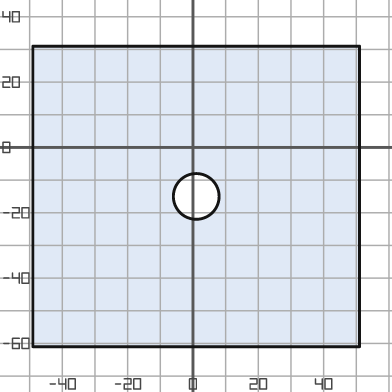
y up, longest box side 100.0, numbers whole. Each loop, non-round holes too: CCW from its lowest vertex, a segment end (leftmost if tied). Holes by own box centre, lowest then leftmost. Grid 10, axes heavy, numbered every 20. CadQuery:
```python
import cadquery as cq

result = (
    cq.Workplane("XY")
    .moveTo(-49.0, -61.0)
    .lineTo(51.0, -61.0)
    .lineTo(51.0, 31.0)
    .lineTo(-49.0, 31.0)
    .close()
    .moveTo(1.0, -15.0)
    .circle(7.0)
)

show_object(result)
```